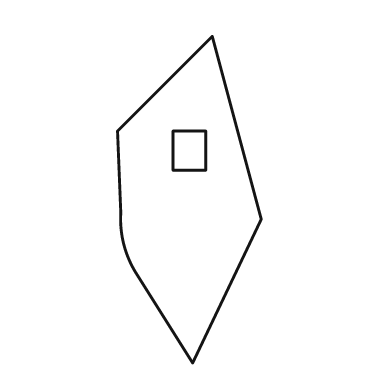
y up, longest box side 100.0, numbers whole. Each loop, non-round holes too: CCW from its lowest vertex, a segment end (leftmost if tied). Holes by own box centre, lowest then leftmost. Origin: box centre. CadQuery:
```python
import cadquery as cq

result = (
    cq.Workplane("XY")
    .moveTo(1.0, -50.0)
    .lineTo(22.0, -6.0)
    .lineTo(7.0, 50.0)
    .lineTo(-22.0, 21.0)
    .lineTo(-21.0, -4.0)
    .threePointArc((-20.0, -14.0), (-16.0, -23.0))
    .close()
    .moveTo(-5.0, 9.0)
    .lineTo(5.0, 9.0)
    .lineTo(5.0, 21.0)
    .lineTo(-5.0, 21.0)
    .close()
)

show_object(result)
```